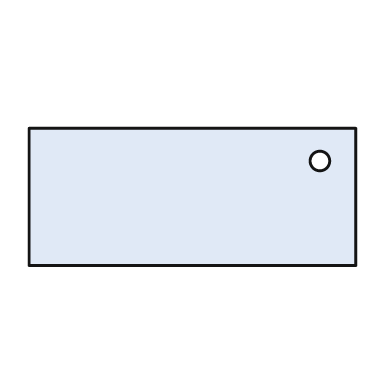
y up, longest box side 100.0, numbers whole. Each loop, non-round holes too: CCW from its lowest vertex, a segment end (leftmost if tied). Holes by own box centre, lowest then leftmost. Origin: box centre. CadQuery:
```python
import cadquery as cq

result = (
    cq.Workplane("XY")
    .moveTo(-50.0, -21.0)
    .lineTo(50.0, -21.0)
    .lineTo(50.0, 21.0)
    .lineTo(-50.0, 21.0)
    .close()
    .moveTo(39.0, 11.0)
    .circle(3.0)
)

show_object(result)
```